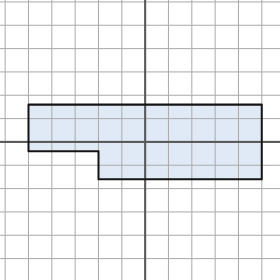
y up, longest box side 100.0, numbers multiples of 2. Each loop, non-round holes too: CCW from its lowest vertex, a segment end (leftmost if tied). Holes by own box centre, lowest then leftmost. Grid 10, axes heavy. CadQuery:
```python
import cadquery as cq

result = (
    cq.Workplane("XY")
    .moveTo(-20.0, -16.0)
    .lineTo(50.0, -16.0)
    .lineTo(50.0, 16.0)
    .lineTo(-50.0, 16.0)
    .lineTo(-50.0, -4.0)
    .lineTo(-20.0, -4.0)
    .close()
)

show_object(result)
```